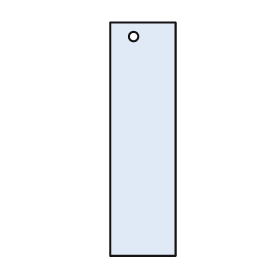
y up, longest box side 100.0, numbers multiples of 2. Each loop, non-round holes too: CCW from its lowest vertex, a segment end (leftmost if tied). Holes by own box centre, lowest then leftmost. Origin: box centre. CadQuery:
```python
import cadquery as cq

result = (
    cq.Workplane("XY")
    .moveTo(-14.0, -50.0)
    .lineTo(14.0, -50.0)
    .lineTo(14.0, 50.0)
    .lineTo(-14.0, 50.0)
    .close()
    .moveTo(-4.0, 44.0)
    .circle(2.0)
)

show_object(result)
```